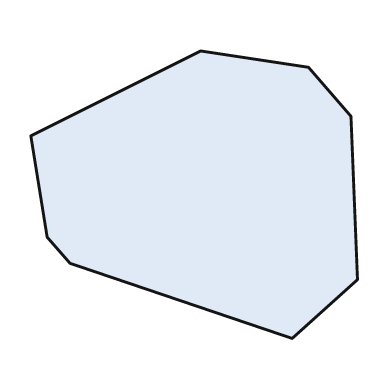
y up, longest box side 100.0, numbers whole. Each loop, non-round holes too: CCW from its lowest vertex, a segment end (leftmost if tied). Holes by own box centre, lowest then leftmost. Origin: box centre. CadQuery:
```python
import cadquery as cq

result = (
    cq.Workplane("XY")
    .moveTo(30.0, -44.0)
    .lineTo(50.0, -26.0)
    .lineTo(48.0, 24.0)
    .lineTo(35.0, 39.0)
    .lineTo(2.0, 44.0)
    .lineTo(-50.0, 18.0)
    .lineTo(-45.0, -13.0)
    .lineTo(-38.0, -21.0)
    .close()
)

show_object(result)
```